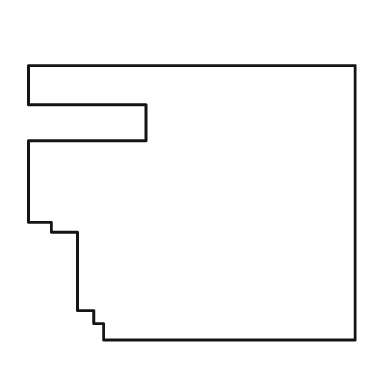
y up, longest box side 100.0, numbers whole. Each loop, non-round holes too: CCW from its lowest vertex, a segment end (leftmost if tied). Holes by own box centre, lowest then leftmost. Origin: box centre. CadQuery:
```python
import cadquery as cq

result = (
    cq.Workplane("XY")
    .moveTo(-27.0, -42.0)
    .lineTo(50.0, -42.0)
    .lineTo(50.0, 42.0)
    .lineTo(-50.0, 42.0)
    .lineTo(-50.0, 30.0)
    .lineTo(-14.0, 30.0)
    .lineTo(-14.0, 19.0)
    .lineTo(-50.0, 19.0)
    .lineTo(-50.0, -6.0)
    .lineTo(-43.0, -6.0)
    .lineTo(-43.0, -9.0)
    .lineTo(-35.0, -9.0)
    .lineTo(-35.0, -33.0)
    .lineTo(-30.0, -33.0)
    .lineTo(-30.0, -37.0)
    .lineTo(-27.0, -37.0)
    .close()
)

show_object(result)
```